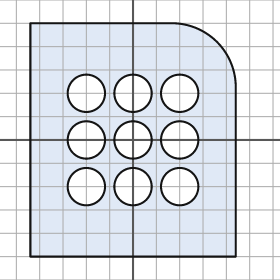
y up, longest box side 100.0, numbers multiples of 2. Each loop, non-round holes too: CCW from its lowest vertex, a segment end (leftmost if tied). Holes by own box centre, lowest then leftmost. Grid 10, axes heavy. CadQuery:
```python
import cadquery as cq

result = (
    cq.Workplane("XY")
    .moveTo(-44.0, -50.0)
    .lineTo(44.0, -50.0)
    .lineTo(44.0, 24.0)
    .threePointArc((36.0, 42.0), (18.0, 50.0))
    .lineTo(-44.0, 50.0)
    .close()
    .moveTo(-20.0, -20.0)
    .circle(8.0)
    .moveTo(0.0, -20.0)
    .circle(8.0)
    .moveTo(20.0, -20.0)
    .circle(8.0)
    .moveTo(-20.0, 0.0)
    .circle(8.0)
    .moveTo(0.0, 0.0)
    .circle(8.0)
    .moveTo(20.0, 0.0)
    .circle(8.0)
    .moveTo(-20.0, 20.0)
    .circle(8.0)
    .moveTo(0.0, 20.0)
    .circle(8.0)
    .moveTo(20.0, 20.0)
    .circle(8.0)
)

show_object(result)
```